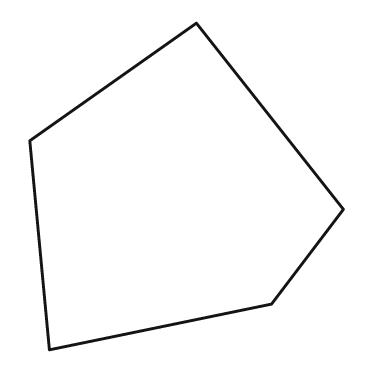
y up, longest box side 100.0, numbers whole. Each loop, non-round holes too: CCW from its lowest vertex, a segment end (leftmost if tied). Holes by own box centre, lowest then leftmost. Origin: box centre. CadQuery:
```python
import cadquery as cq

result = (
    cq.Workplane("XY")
    .moveTo(-42.0, -50.0)
    .lineTo(26.0, -36.0)
    .lineTo(48.0, -7.0)
    .lineTo(3.0, 50.0)
    .lineTo(-48.0, 14.0)
    .close()
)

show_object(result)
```